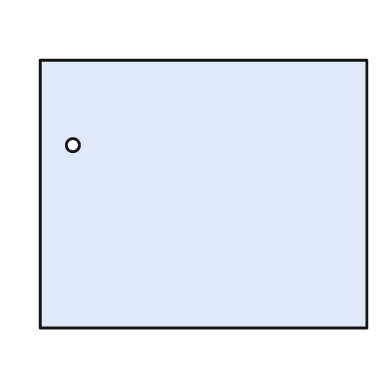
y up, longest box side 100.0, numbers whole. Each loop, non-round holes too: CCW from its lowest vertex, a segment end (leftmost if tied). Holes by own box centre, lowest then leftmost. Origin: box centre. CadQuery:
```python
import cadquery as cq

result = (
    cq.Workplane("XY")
    .moveTo(-50.0, -41.0)
    .lineTo(50.0, -41.0)
    .lineTo(50.0, 41.0)
    .lineTo(-50.0, 41.0)
    .close()
    .moveTo(-40.0, 15.0)
    .circle(2.0)
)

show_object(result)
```